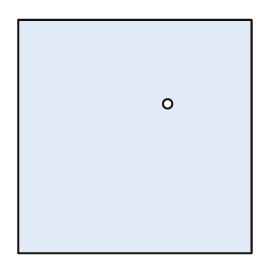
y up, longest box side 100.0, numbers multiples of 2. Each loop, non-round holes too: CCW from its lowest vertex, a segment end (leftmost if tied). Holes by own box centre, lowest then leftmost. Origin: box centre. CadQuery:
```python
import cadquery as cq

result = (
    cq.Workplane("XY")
    .moveTo(-50.0, -50.0)
    .lineTo(50.0, -50.0)
    .lineTo(50.0, 50.0)
    .lineTo(-50.0, 50.0)
    .close()
    .moveTo(14.0, 14.0)
    .circle(2.0)
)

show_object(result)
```